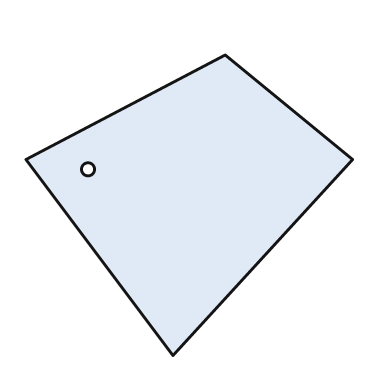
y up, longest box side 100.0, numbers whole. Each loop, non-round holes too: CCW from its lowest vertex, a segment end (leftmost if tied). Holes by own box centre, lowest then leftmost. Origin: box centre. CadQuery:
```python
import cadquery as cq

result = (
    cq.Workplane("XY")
    .moveTo(-5.0, -46.0)
    .lineTo(50.0, 14.0)
    .lineTo(11.0, 46.0)
    .lineTo(-50.0, 14.0)
    .close()
    .moveTo(-31.0, 11.0)
    .circle(2.0)
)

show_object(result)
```